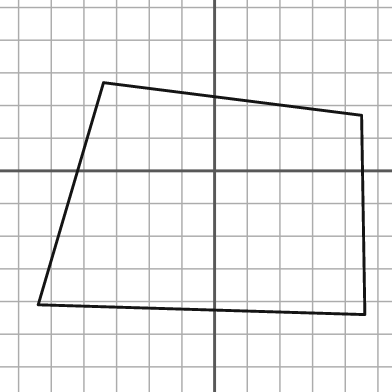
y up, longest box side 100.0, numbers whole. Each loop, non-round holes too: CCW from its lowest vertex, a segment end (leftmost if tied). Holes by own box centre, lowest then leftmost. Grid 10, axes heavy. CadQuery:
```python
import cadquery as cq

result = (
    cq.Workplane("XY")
    .moveTo(46.0, -44.0)
    .lineTo(45.0, 17.0)
    .lineTo(-34.0, 27.0)
    .lineTo(-54.0, -41.0)
    .close()
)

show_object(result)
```